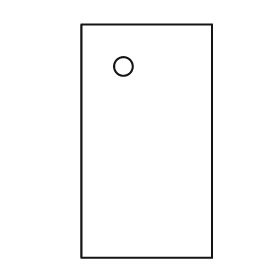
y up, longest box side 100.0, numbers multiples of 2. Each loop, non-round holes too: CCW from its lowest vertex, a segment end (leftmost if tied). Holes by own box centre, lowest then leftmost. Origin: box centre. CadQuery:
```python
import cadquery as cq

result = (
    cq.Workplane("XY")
    .moveTo(-28.0, -50.0)
    .lineTo(28.0, -50.0)
    .lineTo(28.0, 50.0)
    .lineTo(-28.0, 50.0)
    .close()
    .moveTo(-10.0, 32.0)
    .circle(4.0)
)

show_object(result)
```